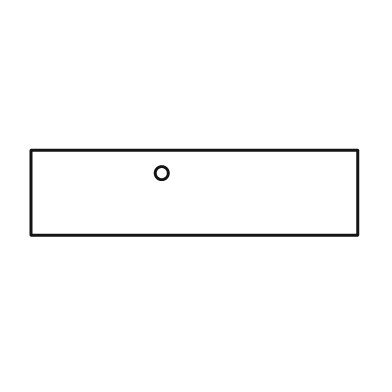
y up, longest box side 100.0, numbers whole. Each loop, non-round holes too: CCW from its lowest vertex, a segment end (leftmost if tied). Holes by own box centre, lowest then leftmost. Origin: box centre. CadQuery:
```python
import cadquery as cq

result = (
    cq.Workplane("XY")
    .moveTo(-50.0, -13.0)
    .lineTo(50.0, -13.0)
    .lineTo(50.0, 13.0)
    .lineTo(-50.0, 13.0)
    .close()
    .moveTo(-10.0, 6.0)
    .circle(2.0)
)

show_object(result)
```